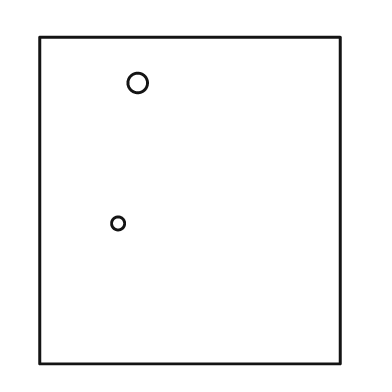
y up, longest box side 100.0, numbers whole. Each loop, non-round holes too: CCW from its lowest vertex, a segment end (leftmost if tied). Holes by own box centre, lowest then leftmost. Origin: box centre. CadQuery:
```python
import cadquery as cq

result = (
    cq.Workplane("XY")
    .moveTo(-46.0, -50.0)
    .lineTo(46.0, -50.0)
    .lineTo(46.0, 50.0)
    .lineTo(-46.0, 50.0)
    .close()
    .moveTo(-22.0, -7.0)
    .circle(2.0)
    .moveTo(-16.0, 36.0)
    .circle(3.0)
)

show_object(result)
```